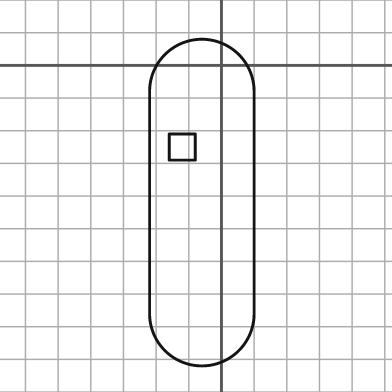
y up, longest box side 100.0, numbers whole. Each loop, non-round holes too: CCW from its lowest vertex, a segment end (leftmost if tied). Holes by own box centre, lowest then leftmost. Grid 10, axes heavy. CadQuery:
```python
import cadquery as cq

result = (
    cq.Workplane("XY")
    .moveTo(-22.0, -76.0)
    .threePointArc((-6.0, -92.0), (10.0, -76.0))
    .lineTo(10.0, -8.0)
    .threePointArc((-6.0, 8.0), (-22.0, -8.0))
    .close()
    .moveTo(-16.0, -29.0)
    .lineTo(-8.0, -29.0)
    .lineTo(-8.0, -21.0)
    .lineTo(-16.0, -21.0)
    .close()
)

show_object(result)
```